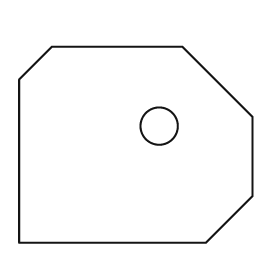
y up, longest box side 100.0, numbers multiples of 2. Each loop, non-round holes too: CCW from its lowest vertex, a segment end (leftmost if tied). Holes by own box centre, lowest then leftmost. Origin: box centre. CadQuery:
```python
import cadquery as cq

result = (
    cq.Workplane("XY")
    .moveTo(-50.0, -42.0)
    .lineTo(30.0, -42.0)
    .lineTo(50.0, -22.0)
    .lineTo(50.0, 12.0)
    .lineTo(20.0, 42.0)
    .lineTo(-36.0, 42.0)
    .lineTo(-50.0, 28.0)
    .close()
    .moveTo(10.0, 8.0)
    .circle(8.0)
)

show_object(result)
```